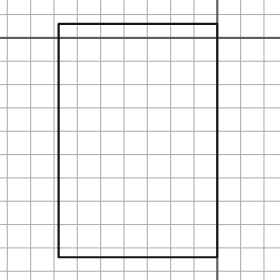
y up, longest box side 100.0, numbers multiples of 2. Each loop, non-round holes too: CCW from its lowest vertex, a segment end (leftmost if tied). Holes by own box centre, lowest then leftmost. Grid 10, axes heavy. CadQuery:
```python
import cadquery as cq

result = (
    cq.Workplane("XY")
    .moveTo(-68.0, -94.0)
    .lineTo(0.0, -94.0)
    .lineTo(0.0, 6.0)
    .lineTo(-68.0, 6.0)
    .close()
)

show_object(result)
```